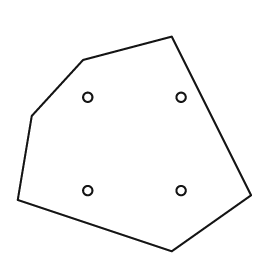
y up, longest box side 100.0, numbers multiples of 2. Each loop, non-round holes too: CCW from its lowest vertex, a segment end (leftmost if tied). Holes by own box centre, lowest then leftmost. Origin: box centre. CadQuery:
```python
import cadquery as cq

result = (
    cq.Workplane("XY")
    .moveTo(16.0, -46.0)
    .lineTo(50.0, -22.0)
    .lineTo(16.0, 46.0)
    .lineTo(-22.0, 36.0)
    .lineTo(-44.0, 12.0)
    .lineTo(-50.0, -24.0)
    .close()
    .moveTo(-20.0, -20.0)
    .circle(2.0)
    .moveTo(20.0, -20.0)
    .circle(2.0)
    .moveTo(-20.0, 20.0)
    .circle(2.0)
    .moveTo(20.0, 20.0)
    .circle(2.0)
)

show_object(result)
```